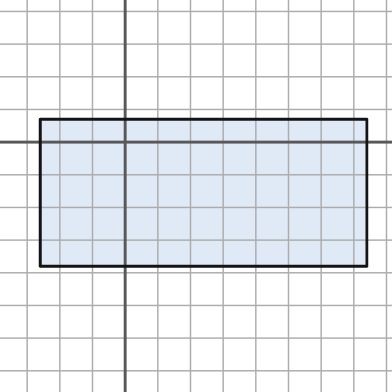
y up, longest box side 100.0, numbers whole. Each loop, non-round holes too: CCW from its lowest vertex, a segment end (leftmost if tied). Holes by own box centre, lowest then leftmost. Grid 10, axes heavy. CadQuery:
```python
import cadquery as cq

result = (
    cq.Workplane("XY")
    .moveTo(-26.0, -38.0)
    .lineTo(74.0, -38.0)
    .lineTo(74.0, 7.0)
    .lineTo(-26.0, 7.0)
    .close()
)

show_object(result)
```